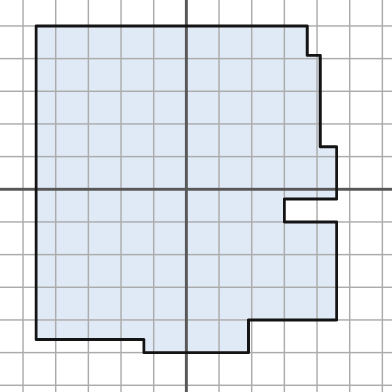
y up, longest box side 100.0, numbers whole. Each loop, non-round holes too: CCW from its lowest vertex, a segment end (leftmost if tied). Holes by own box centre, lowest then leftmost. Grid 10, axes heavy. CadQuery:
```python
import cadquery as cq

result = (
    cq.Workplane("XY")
    .moveTo(-13.0, -50.0)
    .lineTo(19.0, -50.0)
    .lineTo(19.0, -40.0)
    .lineTo(46.0, -40.0)
    .lineTo(46.0, -10.0)
    .lineTo(30.0, -10.0)
    .lineTo(30.0, -3.0)
    .lineTo(46.0, -3.0)
    .lineTo(46.0, 13.0)
    .lineTo(41.0, 13.0)
    .lineTo(41.0, 41.0)
    .lineTo(37.0, 41.0)
    .lineTo(37.0, 50.0)
    .lineTo(-46.0, 50.0)
    .lineTo(-46.0, -46.0)
    .lineTo(-13.0, -46.0)
    .close()
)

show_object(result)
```